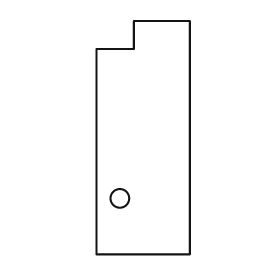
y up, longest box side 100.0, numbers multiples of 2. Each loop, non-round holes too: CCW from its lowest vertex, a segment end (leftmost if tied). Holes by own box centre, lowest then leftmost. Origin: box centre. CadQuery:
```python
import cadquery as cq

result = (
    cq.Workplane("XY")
    .moveTo(-20.0, -50.0)
    .lineTo(20.0, -50.0)
    .lineTo(20.0, 50.0)
    .lineTo(-4.0, 50.0)
    .lineTo(-4.0, 38.0)
    .lineTo(-20.0, 38.0)
    .close()
    .moveTo(-10.0, -26.0)
    .circle(4.0)
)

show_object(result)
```